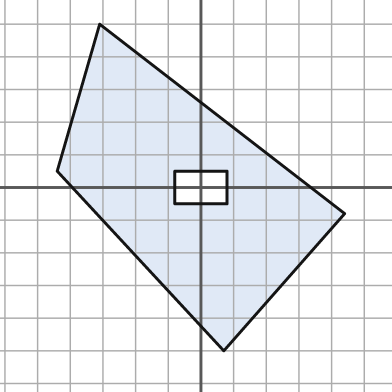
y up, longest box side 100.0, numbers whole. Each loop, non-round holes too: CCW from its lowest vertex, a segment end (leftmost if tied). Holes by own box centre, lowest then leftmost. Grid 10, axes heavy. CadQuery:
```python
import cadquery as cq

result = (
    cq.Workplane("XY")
    .moveTo(7.0, -50.0)
    .lineTo(44.0, -8.0)
    .lineTo(-31.0, 50.0)
    .lineTo(-44.0, 5.0)
    .close()
    .moveTo(-8.0, -5.0)
    .lineTo(8.0, -5.0)
    .lineTo(8.0, 5.0)
    .lineTo(-8.0, 5.0)
    .close()
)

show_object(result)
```